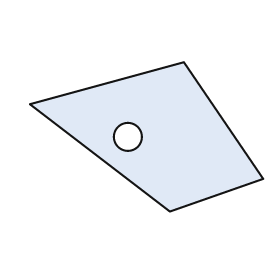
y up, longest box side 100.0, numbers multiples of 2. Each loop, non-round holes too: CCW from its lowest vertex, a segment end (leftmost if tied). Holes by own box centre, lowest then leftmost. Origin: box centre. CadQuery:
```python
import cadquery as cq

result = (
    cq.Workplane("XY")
    .moveTo(10.0, -32.0)
    .lineTo(50.0, -18.0)
    .lineTo(16.0, 32.0)
    .lineTo(-50.0, 14.0)
    .close()
    .moveTo(-8.0, 0.0)
    .circle(6.0)
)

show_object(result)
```